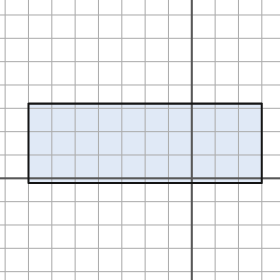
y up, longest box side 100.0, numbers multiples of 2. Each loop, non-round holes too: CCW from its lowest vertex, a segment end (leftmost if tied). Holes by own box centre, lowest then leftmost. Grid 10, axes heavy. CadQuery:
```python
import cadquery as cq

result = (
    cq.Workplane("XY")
    .moveTo(-70.0, -2.0)
    .lineTo(30.0, -2.0)
    .lineTo(30.0, 32.0)
    .lineTo(-70.0, 32.0)
    .close()
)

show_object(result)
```